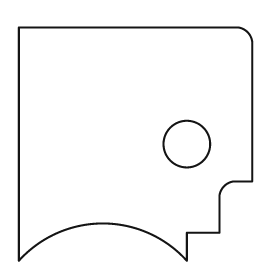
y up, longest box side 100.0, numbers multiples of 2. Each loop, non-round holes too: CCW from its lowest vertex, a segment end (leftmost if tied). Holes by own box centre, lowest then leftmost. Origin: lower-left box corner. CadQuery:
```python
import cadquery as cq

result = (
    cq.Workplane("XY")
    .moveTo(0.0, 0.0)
    .threePointArc((36.0, 16.0), (72.0, 0.0))
    .lineTo(72.0, 12.0)
    .lineTo(86.0, 12.0)
    .lineTo(86.0, 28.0)
    .threePointArc((88.0, 32.0), (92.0, 34.0))
    .lineTo(100.0, 34.0)
    .lineTo(100.0, 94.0)
    .threePointArc((98.0, 98.0), (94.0, 100.0))
    .lineTo(0.0, 100.0)
    .close()
    .moveTo(72.0, 50.0)
    .circle(10.0)
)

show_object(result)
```